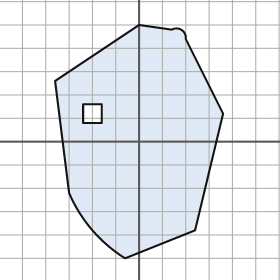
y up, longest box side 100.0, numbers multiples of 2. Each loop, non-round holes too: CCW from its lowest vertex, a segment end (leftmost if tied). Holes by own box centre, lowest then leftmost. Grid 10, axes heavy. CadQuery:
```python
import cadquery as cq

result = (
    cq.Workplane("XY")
    .moveTo(-6.0, -50.0)
    .lineTo(24.0, -38.0)
    .lineTo(36.0, 12.0)
    .lineTo(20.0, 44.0)
    .threePointArc((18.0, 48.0), (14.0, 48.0))
    .lineTo(0.0, 50.0)
    .lineTo(-36.0, 26.0)
    .lineTo(-30.0, -22.0)
    .threePointArc((-20.0, -38.0), (-6.0, -50.0))
    .close()
    .moveTo(-24.0, 8.0)
    .lineTo(-16.0, 8.0)
    .lineTo(-16.0, 16.0)
    .lineTo(-24.0, 16.0)
    .close()
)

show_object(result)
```